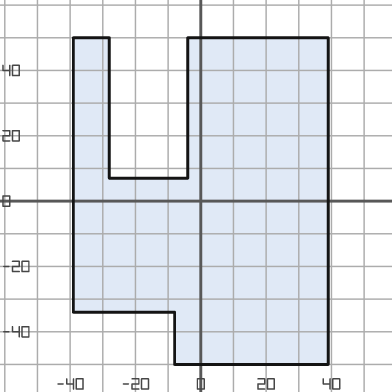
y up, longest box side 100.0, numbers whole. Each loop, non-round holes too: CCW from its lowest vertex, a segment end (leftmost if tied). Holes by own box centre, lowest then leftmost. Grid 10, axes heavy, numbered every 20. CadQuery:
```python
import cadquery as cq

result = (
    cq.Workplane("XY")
    .moveTo(-8.0, -50.0)
    .lineTo(39.0, -50.0)
    .lineTo(39.0, 50.0)
    .lineTo(-4.0, 50.0)
    .lineTo(-4.0, 7.0)
    .lineTo(-28.0, 7.0)
    .lineTo(-28.0, 50.0)
    .lineTo(-39.0, 50.0)
    .lineTo(-39.0, -34.0)
    .lineTo(-8.0, -34.0)
    .close()
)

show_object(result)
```